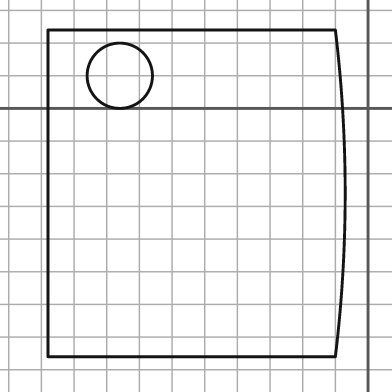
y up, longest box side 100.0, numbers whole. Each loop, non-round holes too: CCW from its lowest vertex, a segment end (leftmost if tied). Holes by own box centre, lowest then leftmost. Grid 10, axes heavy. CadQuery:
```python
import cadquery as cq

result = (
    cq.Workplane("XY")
    .moveTo(-98.0, -76.0)
    .lineTo(-10.0, -76.0)
    .threePointArc((-7.0, -26.0), (-10.0, 24.0))
    .lineTo(-98.0, 24.0)
    .close()
    .moveTo(-76.0, 10.0)
    .circle(10.0)
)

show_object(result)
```